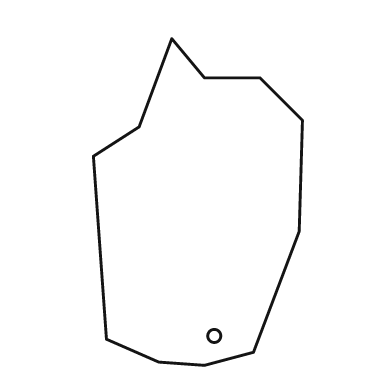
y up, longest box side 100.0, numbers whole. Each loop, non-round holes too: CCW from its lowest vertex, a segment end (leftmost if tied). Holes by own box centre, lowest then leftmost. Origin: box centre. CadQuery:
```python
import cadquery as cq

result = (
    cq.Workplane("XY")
    .moveTo(2.0, -50.0)
    .lineTo(17.0, -46.0)
    .lineTo(31.0, -9.0)
    .lineTo(32.0, 25.0)
    .lineTo(19.0, 38.0)
    .lineTo(2.0, 38.0)
    .lineTo(-8.0, 50.0)
    .lineTo(-18.0, 23.0)
    .lineTo(-32.0, 14.0)
    .lineTo(-28.0, -42.0)
    .lineTo(-12.0, -49.0)
    .close()
    .moveTo(5.0, -41.0)
    .circle(2.0)
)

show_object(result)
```